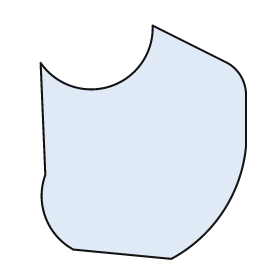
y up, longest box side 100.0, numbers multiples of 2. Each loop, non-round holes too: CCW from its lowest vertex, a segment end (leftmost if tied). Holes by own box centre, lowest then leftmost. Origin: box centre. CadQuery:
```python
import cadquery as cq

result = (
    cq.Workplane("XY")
    .moveTo(12.0, -50.0)
    .threePointArc((34.0, -30.0), (44.0, -2.0))
    .lineTo(44.0, 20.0)
    .threePointArc((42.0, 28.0), (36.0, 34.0))
    .lineTo(4.0, 50.0)
    .threePointArc((-14.0, 24.0), (-44.0, 34.0))
    .lineTo(-42.0, -14.0)
    .threePointArc((-42.0, -32.0), (-30.0, -46.0))
    .close()
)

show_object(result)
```